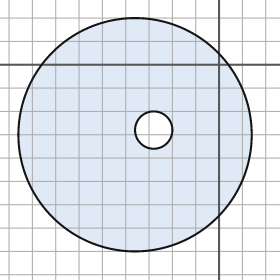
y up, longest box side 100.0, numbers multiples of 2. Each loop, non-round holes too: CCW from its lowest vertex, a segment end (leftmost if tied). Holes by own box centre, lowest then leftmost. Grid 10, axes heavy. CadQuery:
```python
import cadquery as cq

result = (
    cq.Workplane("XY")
    .moveTo(-36.0, -30.0)
    .circle(50.0)
    .moveTo(-28.0, -28.0)
    .circle(8.0)
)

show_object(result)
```